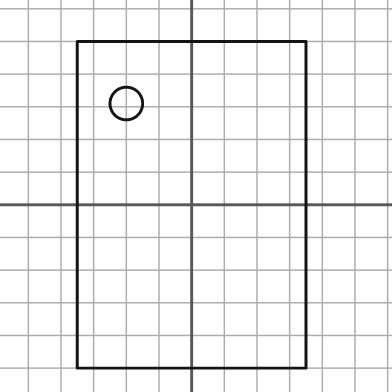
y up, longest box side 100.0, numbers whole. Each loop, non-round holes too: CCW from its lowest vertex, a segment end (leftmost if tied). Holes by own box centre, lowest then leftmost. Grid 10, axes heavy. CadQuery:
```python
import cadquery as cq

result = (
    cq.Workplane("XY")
    .moveTo(-35.0, -50.0)
    .lineTo(35.0, -50.0)
    .lineTo(35.0, 50.0)
    .lineTo(-35.0, 50.0)
    .close()
    .moveTo(-20.0, 31.0)
    .circle(5.0)
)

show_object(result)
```